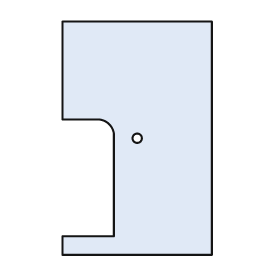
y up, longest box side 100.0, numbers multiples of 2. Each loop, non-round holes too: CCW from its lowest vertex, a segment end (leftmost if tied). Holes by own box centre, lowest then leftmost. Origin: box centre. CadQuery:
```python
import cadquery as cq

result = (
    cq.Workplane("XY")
    .moveTo(-32.0, -50.0)
    .lineTo(32.0, -50.0)
    .lineTo(32.0, 50.0)
    .lineTo(-32.0, 50.0)
    .lineTo(-32.0, 8.0)
    .lineTo(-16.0, 8.0)
    .threePointArc((-12.0, 6.0), (-10.0, 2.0))
    .lineTo(-10.0, -42.0)
    .lineTo(-32.0, -42.0)
    .close()
    .moveTo(0.0, 0.0)
    .circle(2.0)
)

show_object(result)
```